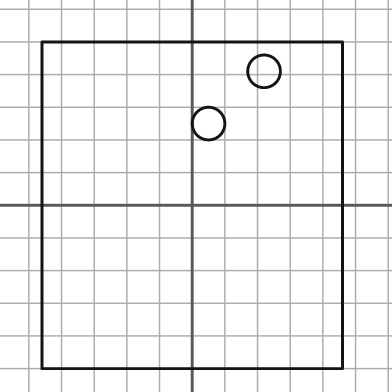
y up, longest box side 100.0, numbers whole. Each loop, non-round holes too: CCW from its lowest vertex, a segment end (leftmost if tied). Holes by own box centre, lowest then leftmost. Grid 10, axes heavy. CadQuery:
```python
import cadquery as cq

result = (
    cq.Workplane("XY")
    .moveTo(-46.0, -50.0)
    .lineTo(46.0, -50.0)
    .lineTo(46.0, 50.0)
    .lineTo(-46.0, 50.0)
    .close()
    .moveTo(5.0, 25.0)
    .circle(5.0)
    .moveTo(22.0, 41.0)
    .circle(5.0)
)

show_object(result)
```